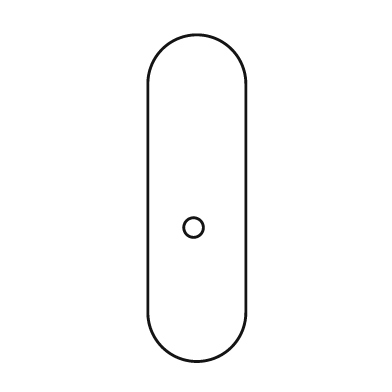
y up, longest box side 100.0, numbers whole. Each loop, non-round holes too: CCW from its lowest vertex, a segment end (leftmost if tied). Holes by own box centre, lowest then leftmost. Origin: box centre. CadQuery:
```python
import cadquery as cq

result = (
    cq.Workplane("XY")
    .moveTo(-15.0, -35.0)
    .threePointArc((0.0, -50.0), (15.0, -35.0))
    .lineTo(15.0, 35.0)
    .threePointArc((0.0, 50.0), (-15.0, 35.0))
    .close()
    .moveTo(-1.0, -9.0)
    .circle(3.0)
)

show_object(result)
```